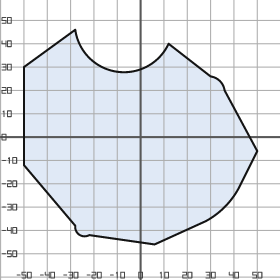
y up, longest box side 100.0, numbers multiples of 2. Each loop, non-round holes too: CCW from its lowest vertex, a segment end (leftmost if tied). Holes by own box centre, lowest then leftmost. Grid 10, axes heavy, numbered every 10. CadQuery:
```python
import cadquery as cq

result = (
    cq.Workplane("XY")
    .moveTo(6.0, -46.0)
    .lineTo(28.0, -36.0)
    .threePointArc((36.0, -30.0), (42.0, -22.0))
    .lineTo(50.0, -6.0)
    .lineTo(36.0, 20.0)
    .threePointArc((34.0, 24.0), (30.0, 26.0))
    .lineTo(12.0, 40.0)
    .threePointArc((-10.0, 28.0), (-28.0, 46.0))
    .lineTo(-50.0, 30.0)
    .lineTo(-50.0, -12.0)
    .lineTo(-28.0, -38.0)
    .threePointArc((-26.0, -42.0), (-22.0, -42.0))
    .close()
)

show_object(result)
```